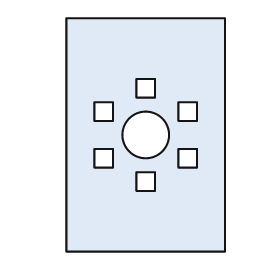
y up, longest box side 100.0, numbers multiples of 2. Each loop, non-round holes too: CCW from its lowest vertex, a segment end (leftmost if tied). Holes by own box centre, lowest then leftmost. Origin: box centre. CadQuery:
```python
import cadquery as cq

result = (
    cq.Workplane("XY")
    .moveTo(-34.0, -50.0)
    .lineTo(34.0, -50.0)
    .lineTo(34.0, 50.0)
    .lineTo(-34.0, 50.0)
    .close()
    .moveTo(-4.0, -24.0)
    .lineTo(4.0, -24.0)
    .lineTo(4.0, -16.0)
    .lineTo(-4.0, -16.0)
    .close()
    .moveTo(-22.0, -14.0)
    .lineTo(-14.0, -14.0)
    .lineTo(-14.0, -6.0)
    .lineTo(-22.0, -6.0)
    .close()
    .moveTo(14.0, -14.0)
    .lineTo(22.0, -14.0)
    .lineTo(22.0, -6.0)
    .lineTo(14.0, -6.0)
    .close()
    .moveTo(0.0, 0.0)
    .circle(10.0)
    .moveTo(-22.0, 6.0)
    .lineTo(-14.0, 6.0)
    .lineTo(-14.0, 14.0)
    .lineTo(-22.0, 14.0)
    .close()
    .moveTo(14.0, 6.0)
    .lineTo(22.0, 6.0)
    .lineTo(22.0, 14.0)
    .lineTo(14.0, 14.0)
    .close()
    .moveTo(-4.0, 16.0)
    .lineTo(4.0, 16.0)
    .lineTo(4.0, 24.0)
    .lineTo(-4.0, 24.0)
    .close()
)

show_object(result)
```